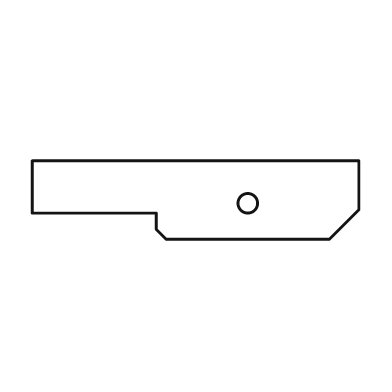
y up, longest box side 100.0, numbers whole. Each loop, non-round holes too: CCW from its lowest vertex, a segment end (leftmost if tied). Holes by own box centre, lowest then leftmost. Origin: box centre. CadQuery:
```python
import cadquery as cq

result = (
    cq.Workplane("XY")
    .moveTo(-9.0, -12.0)
    .lineTo(41.0, -12.0)
    .lineTo(50.0, -3.0)
    .lineTo(50.0, 12.0)
    .lineTo(-50.0, 12.0)
    .lineTo(-50.0, -4.0)
    .lineTo(-12.0, -4.0)
    .lineTo(-12.0, -9.0)
    .close()
    .moveTo(16.0, -1.0)
    .circle(3.0)
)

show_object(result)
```